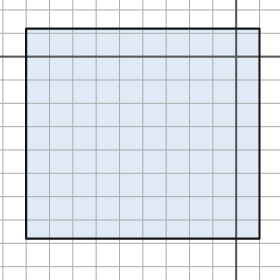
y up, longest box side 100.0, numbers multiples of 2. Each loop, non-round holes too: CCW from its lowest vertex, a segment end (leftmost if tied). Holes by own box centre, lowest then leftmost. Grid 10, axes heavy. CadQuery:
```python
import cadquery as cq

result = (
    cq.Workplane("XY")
    .moveTo(-90.0, -78.0)
    .lineTo(10.0, -78.0)
    .lineTo(10.0, 12.0)
    .lineTo(-90.0, 12.0)
    .close()
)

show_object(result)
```